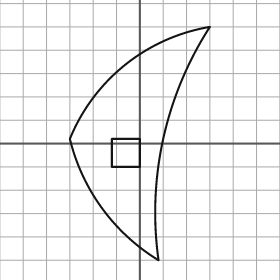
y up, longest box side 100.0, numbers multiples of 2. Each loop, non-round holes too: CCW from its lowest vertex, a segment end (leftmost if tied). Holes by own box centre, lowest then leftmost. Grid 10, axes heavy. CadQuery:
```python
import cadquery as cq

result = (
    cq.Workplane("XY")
    .moveTo(8.0, -50.0)
    .threePointArc((10.0, 2.0), (30.0, 50.0))
    .threePointArc((-6.0, 34.0), (-30.0, 2.0))
    .threePointArc((-16.0, -28.0), (8.0, -50.0))
    .close()
    .moveTo(-12.0, -10.0)
    .lineTo(0.0, -10.0)
    .lineTo(0.0, 2.0)
    .lineTo(-12.0, 2.0)
    .close()
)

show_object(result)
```